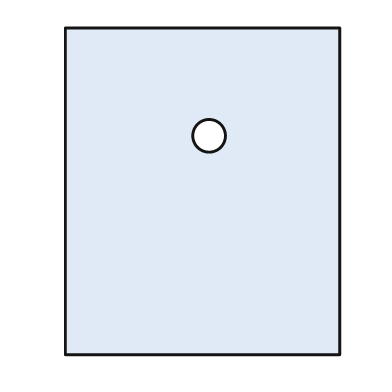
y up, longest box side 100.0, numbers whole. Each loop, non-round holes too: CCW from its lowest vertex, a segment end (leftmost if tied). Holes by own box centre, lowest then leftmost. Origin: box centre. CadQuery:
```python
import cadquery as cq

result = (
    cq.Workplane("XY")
    .moveTo(-42.0, -50.0)
    .lineTo(42.0, -50.0)
    .lineTo(42.0, 50.0)
    .lineTo(-42.0, 50.0)
    .close()
    .moveTo(2.0, 17.0)
    .circle(5.0)
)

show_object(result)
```